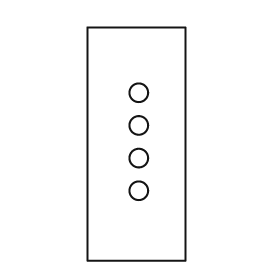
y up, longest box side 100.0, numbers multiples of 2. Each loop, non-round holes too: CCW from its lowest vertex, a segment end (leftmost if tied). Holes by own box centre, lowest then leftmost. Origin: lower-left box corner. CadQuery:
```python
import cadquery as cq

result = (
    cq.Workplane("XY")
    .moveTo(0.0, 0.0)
    .lineTo(42.0, 0.0)
    .lineTo(42.0, 100.0)
    .lineTo(0.0, 100.0)
    .close()
    .moveTo(22.0, 30.0)
    .circle(4.0)
    .moveTo(22.0, 44.0)
    .circle(4.0)
    .moveTo(22.0, 58.0)
    .circle(4.0)
    .moveTo(22.0, 72.0)
    .circle(4.0)
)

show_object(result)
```